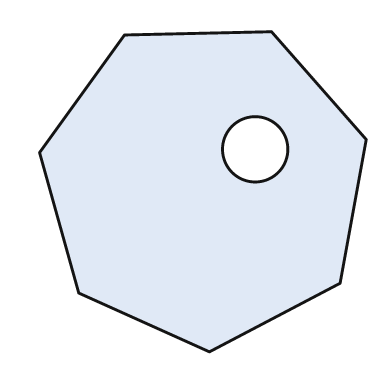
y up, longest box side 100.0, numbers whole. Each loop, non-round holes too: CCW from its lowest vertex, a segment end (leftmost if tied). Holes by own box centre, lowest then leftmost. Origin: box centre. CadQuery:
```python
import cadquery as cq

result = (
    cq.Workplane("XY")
    .moveTo(2.0, -49.0)
    .lineTo(42.0, -28.0)
    .lineTo(50.0, 16.0)
    .lineTo(21.0, 49.0)
    .lineTo(-24.0, 48.0)
    .lineTo(-50.0, 12.0)
    .lineTo(-38.0, -31.0)
    .close()
    .moveTo(16.0, 13.0)
    .circle(10.0)
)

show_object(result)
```